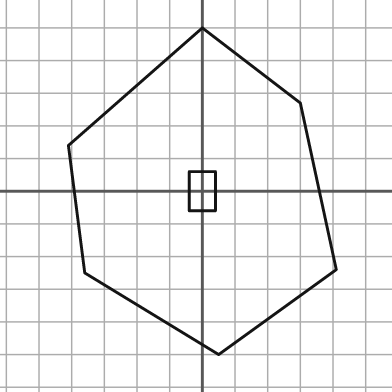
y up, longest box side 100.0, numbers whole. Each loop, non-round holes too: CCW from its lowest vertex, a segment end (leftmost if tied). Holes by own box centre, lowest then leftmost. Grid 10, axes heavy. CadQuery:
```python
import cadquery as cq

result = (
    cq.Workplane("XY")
    .moveTo(5.0, -50.0)
    .lineTo(41.0, -24.0)
    .lineTo(30.0, 27.0)
    .lineTo(0.0, 50.0)
    .lineTo(-41.0, 14.0)
    .lineTo(-36.0, -25.0)
    .close()
    .moveTo(-4.0, -6.0)
    .lineTo(4.0, -6.0)
    .lineTo(4.0, 6.0)
    .lineTo(-4.0, 6.0)
    .close()
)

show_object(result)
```